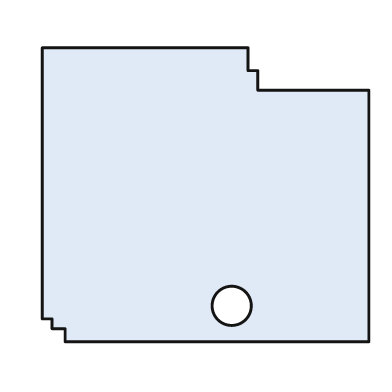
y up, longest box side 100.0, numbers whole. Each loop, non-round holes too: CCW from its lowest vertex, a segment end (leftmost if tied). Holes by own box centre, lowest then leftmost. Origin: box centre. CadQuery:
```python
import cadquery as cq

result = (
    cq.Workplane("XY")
    .moveTo(-43.0, -45.0)
    .lineTo(50.0, -45.0)
    .lineTo(50.0, 32.0)
    .lineTo(16.0, 32.0)
    .lineTo(16.0, 38.0)
    .lineTo(13.0, 38.0)
    .lineTo(13.0, 45.0)
    .lineTo(-50.0, 45.0)
    .lineTo(-50.0, -38.0)
    .lineTo(-47.0, -38.0)
    .lineTo(-47.0, -41.0)
    .lineTo(-43.0, -41.0)
    .close()
    .moveTo(8.0, -34.0)
    .circle(6.0)
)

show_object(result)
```